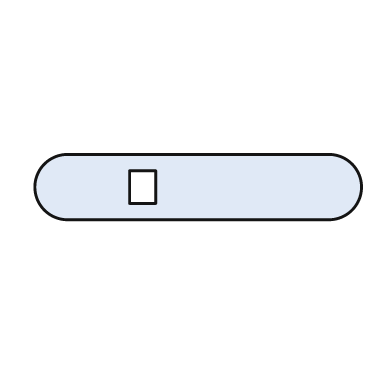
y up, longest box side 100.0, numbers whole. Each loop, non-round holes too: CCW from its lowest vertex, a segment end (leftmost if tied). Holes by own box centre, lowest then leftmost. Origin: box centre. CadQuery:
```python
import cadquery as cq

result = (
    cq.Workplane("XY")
    .moveTo(-40.0, -10.0)
    .lineTo(40.0, -10.0)
    .threePointArc((50.0, 0.0), (40.0, 10.0))
    .lineTo(-40.0, 10.0)
    .threePointArc((-50.0, 0.0), (-40.0, -10.0))
    .close()
    .moveTo(-21.0, -5.0)
    .lineTo(-13.0, -5.0)
    .lineTo(-13.0, 5.0)
    .lineTo(-21.0, 5.0)
    .close()
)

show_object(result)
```